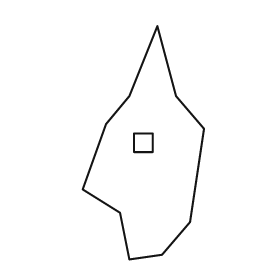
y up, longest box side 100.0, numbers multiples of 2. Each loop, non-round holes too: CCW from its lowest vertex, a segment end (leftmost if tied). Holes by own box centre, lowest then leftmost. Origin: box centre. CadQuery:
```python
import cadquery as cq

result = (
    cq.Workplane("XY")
    .moveTo(-6.0, -50.0)
    .lineTo(8.0, -48.0)
    .lineTo(20.0, -34.0)
    .lineTo(26.0, 6.0)
    .lineTo(14.0, 20.0)
    .lineTo(6.0, 50.0)
    .lineTo(-6.0, 20.0)
    .lineTo(-16.0, 8.0)
    .lineTo(-26.0, -20.0)
    .lineTo(-10.0, -30.0)
    .close()
    .moveTo(-4.0, -4.0)
    .lineTo(4.0, -4.0)
    .lineTo(4.0, 4.0)
    .lineTo(-4.0, 4.0)
    .close()
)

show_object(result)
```